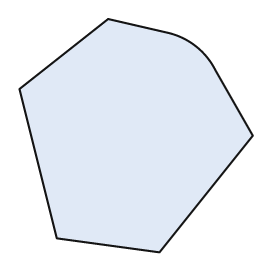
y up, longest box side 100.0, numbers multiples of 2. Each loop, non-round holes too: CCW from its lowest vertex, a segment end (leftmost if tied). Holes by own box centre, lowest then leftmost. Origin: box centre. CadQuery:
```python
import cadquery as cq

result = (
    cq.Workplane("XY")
    .moveTo(10.0, -50.0)
    .lineTo(50.0, 0.0)
    .lineTo(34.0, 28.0)
    .threePointArc((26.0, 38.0), (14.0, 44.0))
    .lineTo(-12.0, 50.0)
    .lineTo(-50.0, 20.0)
    .lineTo(-34.0, -44.0)
    .close()
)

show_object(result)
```